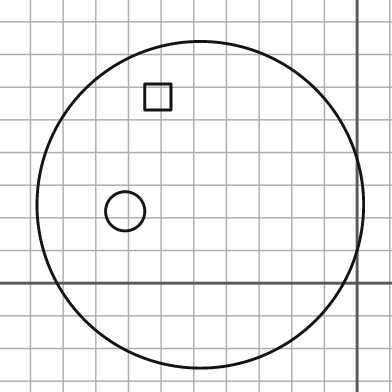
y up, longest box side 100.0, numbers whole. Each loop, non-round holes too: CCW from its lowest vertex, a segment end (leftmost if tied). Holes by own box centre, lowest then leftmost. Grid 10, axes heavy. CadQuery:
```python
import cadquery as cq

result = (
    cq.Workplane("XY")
    .moveTo(-48.0, 24.0)
    .circle(50.0)
    .moveTo(-71.0, 22.0)
    .circle(6.0)
    .moveTo(-65.0, 53.0)
    .lineTo(-57.0, 53.0)
    .lineTo(-57.0, 61.0)
    .lineTo(-65.0, 61.0)
    .close()
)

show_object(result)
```